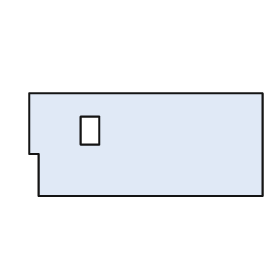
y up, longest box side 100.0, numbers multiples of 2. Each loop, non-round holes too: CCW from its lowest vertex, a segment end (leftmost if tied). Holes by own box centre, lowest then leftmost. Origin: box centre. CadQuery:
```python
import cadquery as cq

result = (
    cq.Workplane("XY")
    .moveTo(-46.0, -22.0)
    .lineTo(50.0, -22.0)
    .lineTo(50.0, 22.0)
    .lineTo(-50.0, 22.0)
    .lineTo(-50.0, -4.0)
    .lineTo(-46.0, -4.0)
    .close()
    .moveTo(-28.0, 0.0)
    .lineTo(-20.0, 0.0)
    .lineTo(-20.0, 12.0)
    .lineTo(-28.0, 12.0)
    .close()
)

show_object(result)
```